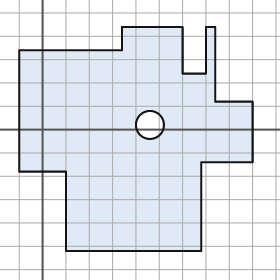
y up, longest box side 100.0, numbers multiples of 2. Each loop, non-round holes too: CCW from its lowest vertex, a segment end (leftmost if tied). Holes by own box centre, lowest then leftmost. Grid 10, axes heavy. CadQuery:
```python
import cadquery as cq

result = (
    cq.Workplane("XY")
    .moveTo(10.0, -52.0)
    .lineTo(68.0, -52.0)
    .lineTo(68.0, -14.0)
    .lineTo(90.0, -14.0)
    .lineTo(90.0, 12.0)
    .lineTo(74.0, 12.0)
    .lineTo(74.0, 44.0)
    .lineTo(70.0, 44.0)
    .lineTo(70.0, 24.0)
    .lineTo(60.0, 24.0)
    .lineTo(60.0, 44.0)
    .lineTo(34.0, 44.0)
    .lineTo(34.0, 34.0)
    .lineTo(-10.0, 34.0)
    .lineTo(-10.0, -18.0)
    .lineTo(10.0, -18.0)
    .close()
    .moveTo(46.0, 2.0)
    .circle(6.0)
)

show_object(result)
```